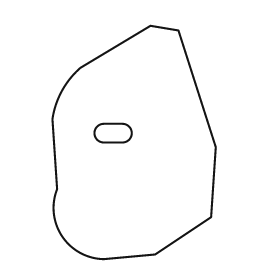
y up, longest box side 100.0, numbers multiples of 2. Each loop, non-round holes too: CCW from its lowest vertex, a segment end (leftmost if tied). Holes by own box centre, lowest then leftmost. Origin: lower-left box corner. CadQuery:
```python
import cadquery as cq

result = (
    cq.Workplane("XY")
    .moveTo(22.0, 0.0)
    .lineTo(44.0, 2.0)
    .lineTo(68.0, 18.0)
    .lineTo(70.0, 48.0)
    .lineTo(54.0, 98.0)
    .lineTo(42.0, 100.0)
    .lineTo(12.0, 82.0)
    .threePointArc((4.0, 72.0), (0.0, 60.0))
    .lineTo(2.0, 30.0)
    .threePointArc((4.0, 10.0), (22.0, 0.0))
    .close()
    .moveTo(22.0, 50.0)
    .lineTo(30.0, 50.0)
    .threePointArc((34.0, 54.0), (30.0, 58.0))
    .lineTo(22.0, 58.0)
    .threePointArc((18.0, 54.0), (22.0, 50.0))
    .close()
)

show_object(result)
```